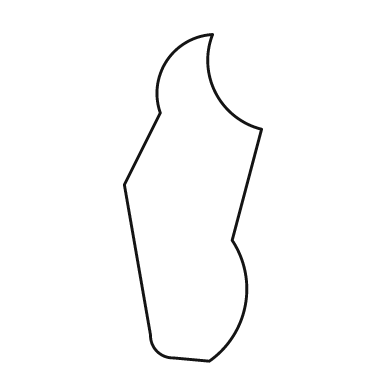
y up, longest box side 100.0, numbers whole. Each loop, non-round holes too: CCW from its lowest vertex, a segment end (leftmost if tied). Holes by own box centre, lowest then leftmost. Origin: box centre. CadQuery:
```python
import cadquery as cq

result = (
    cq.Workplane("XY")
    .moveTo(5.0, -50.0)
    .threePointArc((16.0, -33.0), (12.0, -13.0))
    .lineTo(21.0, 21.0)
    .threePointArc((7.0, 32.0), (6.0, 50.0))
    .threePointArc((-8.0, 42.0), (-10.0, 26.0))
    .lineTo(-21.0, 4.0)
    .lineTo(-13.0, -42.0)
    .threePointArc((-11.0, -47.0), (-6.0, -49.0))
    .close()
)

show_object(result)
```